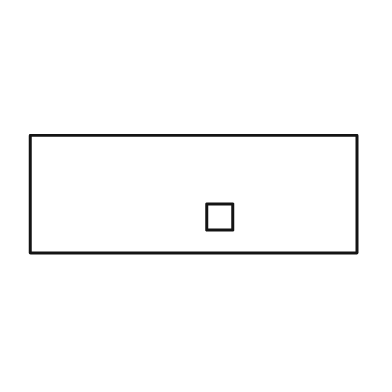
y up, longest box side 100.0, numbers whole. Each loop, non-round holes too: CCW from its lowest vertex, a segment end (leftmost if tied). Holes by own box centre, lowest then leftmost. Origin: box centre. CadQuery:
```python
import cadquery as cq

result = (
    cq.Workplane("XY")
    .moveTo(-50.0, -18.0)
    .lineTo(50.0, -18.0)
    .lineTo(50.0, 18.0)
    .lineTo(-50.0, 18.0)
    .close()
    .moveTo(4.0, -11.0)
    .lineTo(12.0, -11.0)
    .lineTo(12.0, -3.0)
    .lineTo(4.0, -3.0)
    .close()
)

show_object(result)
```